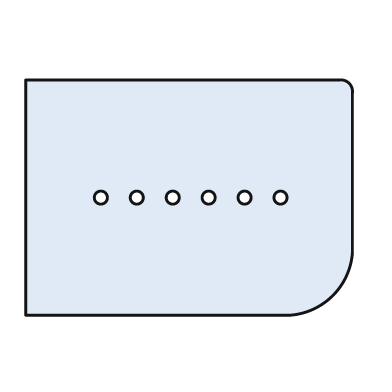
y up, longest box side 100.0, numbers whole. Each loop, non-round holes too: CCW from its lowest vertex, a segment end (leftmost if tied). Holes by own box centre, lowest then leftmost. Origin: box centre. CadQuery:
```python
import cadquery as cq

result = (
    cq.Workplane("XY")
    .moveTo(-50.0, -36.0)
    .lineTo(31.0, -36.0)
    .threePointArc((44.0, -30.0), (50.0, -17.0))
    .lineTo(50.0, 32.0)
    .threePointArc((49.0, 35.0), (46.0, 36.0))
    .lineTo(-50.0, 36.0)
    .close()
    .moveTo(-27.0, 0.0)
    .circle(2.0)
    .moveTo(-16.0, 0.0)
    .circle(2.0)
    .moveTo(-5.0, 0.0)
    .circle(2.0)
    .moveTo(6.0, 0.0)
    .circle(2.0)
    .moveTo(17.0, 0.0)
    .circle(2.0)
    .moveTo(28.0, 0.0)
    .circle(2.0)
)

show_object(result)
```